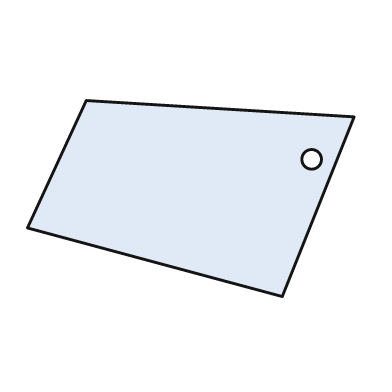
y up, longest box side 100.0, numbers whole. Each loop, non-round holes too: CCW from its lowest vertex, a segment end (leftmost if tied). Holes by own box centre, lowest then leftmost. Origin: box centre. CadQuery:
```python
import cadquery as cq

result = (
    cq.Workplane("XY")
    .moveTo(28.0, -30.0)
    .lineTo(50.0, 25.0)
    .lineTo(-32.0, 30.0)
    .lineTo(-50.0, -9.0)
    .close()
    .moveTo(37.0, 12.0)
    .circle(3.0)
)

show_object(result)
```